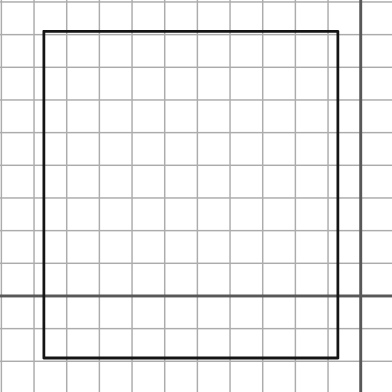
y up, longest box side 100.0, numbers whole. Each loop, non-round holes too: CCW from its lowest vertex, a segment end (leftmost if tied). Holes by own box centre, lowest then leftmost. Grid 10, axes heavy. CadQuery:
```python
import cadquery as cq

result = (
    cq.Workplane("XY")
    .moveTo(-97.0, -19.0)
    .lineTo(-7.0, -19.0)
    .lineTo(-7.0, 81.0)
    .lineTo(-97.0, 81.0)
    .close()
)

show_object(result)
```